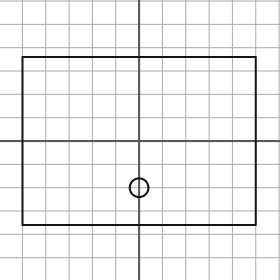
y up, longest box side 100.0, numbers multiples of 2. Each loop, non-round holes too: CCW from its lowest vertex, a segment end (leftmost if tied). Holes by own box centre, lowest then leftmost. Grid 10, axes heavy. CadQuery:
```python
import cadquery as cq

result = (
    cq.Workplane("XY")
    .moveTo(-50.0, -36.0)
    .lineTo(50.0, -36.0)
    .lineTo(50.0, 36.0)
    .lineTo(-50.0, 36.0)
    .close()
    .moveTo(0.0, -20.0)
    .circle(4.0)
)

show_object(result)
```